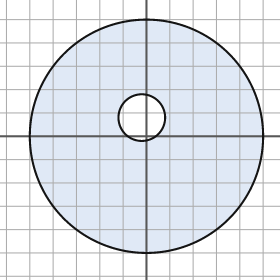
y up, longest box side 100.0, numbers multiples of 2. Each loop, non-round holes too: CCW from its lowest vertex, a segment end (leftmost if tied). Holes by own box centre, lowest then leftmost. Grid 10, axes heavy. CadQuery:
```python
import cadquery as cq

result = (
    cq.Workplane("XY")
    .moveTo(0.0, 0.0)
    .circle(50.0)
    .moveTo(-2.0, 8.0)
    .circle(10.0)
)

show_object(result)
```